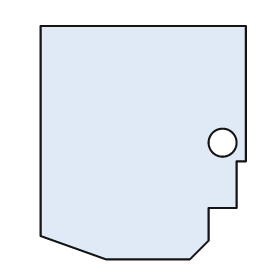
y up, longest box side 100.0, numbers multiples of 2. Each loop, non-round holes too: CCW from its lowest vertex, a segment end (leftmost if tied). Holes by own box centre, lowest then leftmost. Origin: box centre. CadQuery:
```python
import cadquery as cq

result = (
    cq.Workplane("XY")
    .moveTo(-16.0, -50.0)
    .lineTo(20.0, -50.0)
    .lineTo(28.0, -42.0)
    .lineTo(28.0, -28.0)
    .lineTo(40.0, -28.0)
    .lineTo(40.0, -8.0)
    .lineTo(44.0, -8.0)
    .lineTo(44.0, 50.0)
    .lineTo(-44.0, 50.0)
    .lineTo(-44.0, -40.0)
    .close()
    .moveTo(34.0, 0.0)
    .circle(6.0)
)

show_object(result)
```